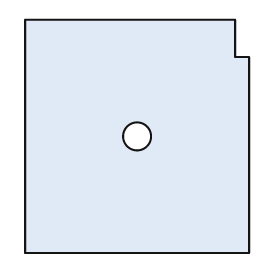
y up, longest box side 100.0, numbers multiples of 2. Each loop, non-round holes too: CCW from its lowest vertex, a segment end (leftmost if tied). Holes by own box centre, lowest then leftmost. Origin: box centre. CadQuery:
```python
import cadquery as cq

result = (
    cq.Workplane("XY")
    .moveTo(-48.0, -50.0)
    .lineTo(48.0, -50.0)
    .lineTo(48.0, 34.0)
    .lineTo(42.0, 34.0)
    .lineTo(42.0, 50.0)
    .lineTo(-48.0, 50.0)
    .close()
    .moveTo(0.0, 0.0)
    .circle(6.0)
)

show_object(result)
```